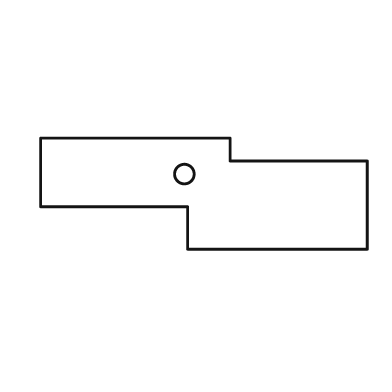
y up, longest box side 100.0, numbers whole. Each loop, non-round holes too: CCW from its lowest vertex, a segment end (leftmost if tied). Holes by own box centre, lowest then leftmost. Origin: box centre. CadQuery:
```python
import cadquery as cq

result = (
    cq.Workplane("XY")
    .moveTo(-5.0, -17.0)
    .lineTo(50.0, -17.0)
    .lineTo(50.0, 10.0)
    .lineTo(8.0, 10.0)
    .lineTo(8.0, 17.0)
    .lineTo(-50.0, 17.0)
    .lineTo(-50.0, -4.0)
    .lineTo(-5.0, -4.0)
    .close()
    .moveTo(-6.0, 6.0)
    .circle(3.0)
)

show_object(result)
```